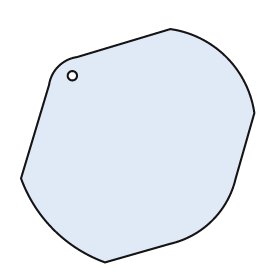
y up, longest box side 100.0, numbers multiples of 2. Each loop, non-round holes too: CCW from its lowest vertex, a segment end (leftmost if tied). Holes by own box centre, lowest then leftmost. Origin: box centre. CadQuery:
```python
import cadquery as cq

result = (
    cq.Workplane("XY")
    .moveTo(-14.0, -50.0)
    .lineTo(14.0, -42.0)
    .threePointArc((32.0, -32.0), (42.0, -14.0))
    .lineTo(50.0, 14.0)
    .threePointArc((38.0, 38.0), (14.0, 50.0))
    .lineTo(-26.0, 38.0)
    .threePointArc((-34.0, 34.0), (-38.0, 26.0))
    .lineTo(-50.0, -14.0)
    .threePointArc((-36.0, -36.0), (-14.0, -50.0))
    .close()
    .moveTo(-28.0, 30.0)
    .circle(2.0)
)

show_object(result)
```